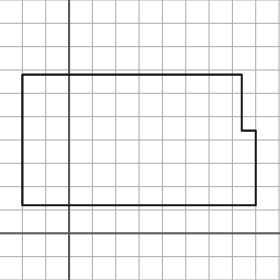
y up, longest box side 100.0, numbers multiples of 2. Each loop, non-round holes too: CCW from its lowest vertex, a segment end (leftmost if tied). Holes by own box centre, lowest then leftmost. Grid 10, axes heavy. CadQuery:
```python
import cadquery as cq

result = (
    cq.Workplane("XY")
    .moveTo(-20.0, 12.0)
    .lineTo(80.0, 12.0)
    .lineTo(80.0, 44.0)
    .lineTo(74.0, 44.0)
    .lineTo(74.0, 68.0)
    .lineTo(-20.0, 68.0)
    .close()
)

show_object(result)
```